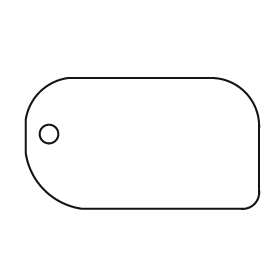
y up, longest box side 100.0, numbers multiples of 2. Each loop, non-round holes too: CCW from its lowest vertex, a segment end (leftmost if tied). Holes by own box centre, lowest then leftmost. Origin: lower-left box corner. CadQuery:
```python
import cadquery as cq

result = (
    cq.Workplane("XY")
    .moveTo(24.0, 0.0)
    .lineTo(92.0, 0.0)
    .threePointArc((98.0, 2.0), (100.0, 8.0))
    .lineTo(100.0, 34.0)
    .threePointArc((94.0, 50.0), (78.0, 56.0))
    .lineTo(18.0, 56.0)
    .threePointArc((6.0, 50.0), (0.0, 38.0))
    .lineTo(0.0, 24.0)
    .threePointArc((8.0, 8.0), (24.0, 0.0))
    .close()
    .moveTo(10.0, 32.0)
    .circle(4.0)
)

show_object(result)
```